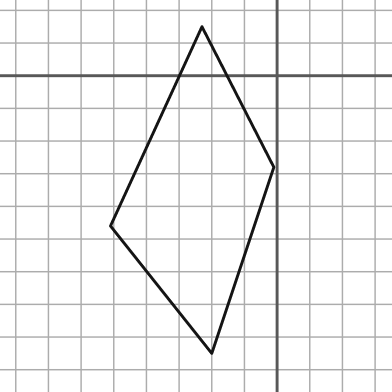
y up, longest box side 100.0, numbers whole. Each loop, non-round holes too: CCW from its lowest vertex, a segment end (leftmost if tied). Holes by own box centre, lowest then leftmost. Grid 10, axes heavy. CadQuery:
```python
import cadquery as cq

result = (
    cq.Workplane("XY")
    .moveTo(-20.0, -85.0)
    .lineTo(-1.0, -28.0)
    .lineTo(-23.0, 15.0)
    .lineTo(-51.0, -46.0)
    .close()
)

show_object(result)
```